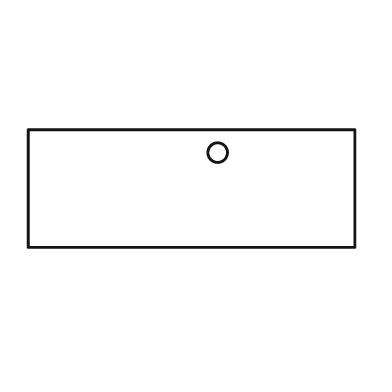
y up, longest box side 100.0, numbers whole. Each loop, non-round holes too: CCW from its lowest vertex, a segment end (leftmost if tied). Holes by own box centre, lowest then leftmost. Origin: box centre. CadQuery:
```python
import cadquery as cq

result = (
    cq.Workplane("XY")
    .moveTo(-50.0, -18.0)
    .lineTo(50.0, -18.0)
    .lineTo(50.0, 18.0)
    .lineTo(-50.0, 18.0)
    .close()
    .moveTo(8.0, 11.0)
    .circle(3.0)
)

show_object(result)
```